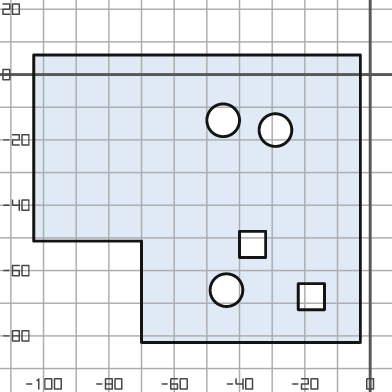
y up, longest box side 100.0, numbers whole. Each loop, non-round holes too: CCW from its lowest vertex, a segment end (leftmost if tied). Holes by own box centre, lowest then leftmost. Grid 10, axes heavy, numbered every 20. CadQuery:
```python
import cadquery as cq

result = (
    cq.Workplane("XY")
    .moveTo(-70.0, -82.0)
    .lineTo(-3.0, -82.0)
    .lineTo(-3.0, 6.0)
    .lineTo(-103.0, 6.0)
    .lineTo(-103.0, -51.0)
    .lineTo(-70.0, -51.0)
    .close()
    .moveTo(-22.0, -72.0)
    .lineTo(-14.0, -72.0)
    .lineTo(-14.0, -64.0)
    .lineTo(-22.0, -64.0)
    .close()
    .moveTo(-44.0, -66.0)
    .circle(5.0)
    .moveTo(-40.0, -56.0)
    .lineTo(-32.0, -56.0)
    .lineTo(-32.0, -48.0)
    .lineTo(-40.0, -48.0)
    .close()
    .moveTo(-29.0, -17.0)
    .circle(5.0)
    .moveTo(-45.0, -14.0)
    .circle(5.0)
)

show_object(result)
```